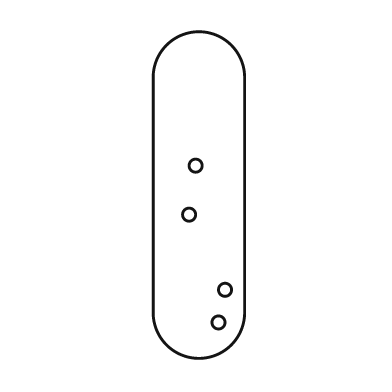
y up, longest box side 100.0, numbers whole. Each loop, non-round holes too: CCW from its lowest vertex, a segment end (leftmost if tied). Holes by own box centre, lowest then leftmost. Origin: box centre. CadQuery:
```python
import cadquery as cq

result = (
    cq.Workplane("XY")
    .moveTo(-14.0, -36.0)
    .threePointArc((0.0, -50.0), (14.0, -36.0))
    .lineTo(14.0, 36.0)
    .threePointArc((0.0, 50.0), (-14.0, 36.0))
    .close()
    .moveTo(6.0, -39.0)
    .circle(2.0)
    .moveTo(8.0, -29.0)
    .circle(2.0)
    .moveTo(-3.0, -6.0)
    .circle(2.0)
    .moveTo(-1.0, 9.0)
    .circle(2.0)
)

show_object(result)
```